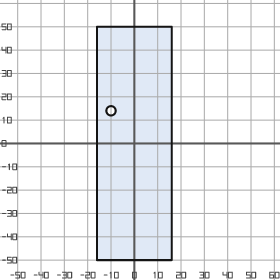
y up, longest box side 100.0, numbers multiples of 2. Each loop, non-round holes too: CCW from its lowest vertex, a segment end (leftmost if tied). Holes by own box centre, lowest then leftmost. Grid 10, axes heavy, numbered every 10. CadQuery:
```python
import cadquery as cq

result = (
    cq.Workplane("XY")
    .moveTo(-16.0, -50.0)
    .lineTo(16.0, -50.0)
    .lineTo(16.0, 50.0)
    .lineTo(-16.0, 50.0)
    .close()
    .moveTo(-10.0, 14.0)
    .circle(2.0)
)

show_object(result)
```